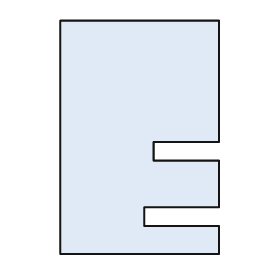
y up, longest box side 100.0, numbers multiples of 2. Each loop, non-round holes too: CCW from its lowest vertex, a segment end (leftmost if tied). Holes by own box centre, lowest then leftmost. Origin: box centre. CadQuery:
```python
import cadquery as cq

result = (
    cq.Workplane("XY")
    .moveTo(-34.0, -50.0)
    .lineTo(34.0, -50.0)
    .lineTo(34.0, -38.0)
    .lineTo(2.0, -38.0)
    .lineTo(2.0, -30.0)
    .lineTo(34.0, -30.0)
    .lineTo(34.0, -10.0)
    .lineTo(6.0, -10.0)
    .lineTo(6.0, -2.0)
    .lineTo(34.0, -2.0)
    .lineTo(34.0, 50.0)
    .lineTo(-34.0, 50.0)
    .close()
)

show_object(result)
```